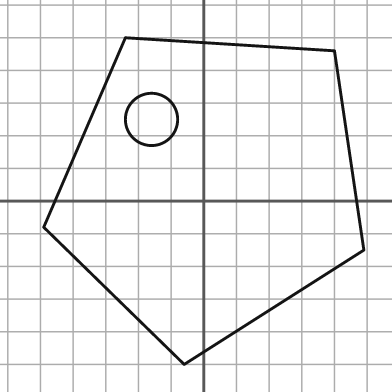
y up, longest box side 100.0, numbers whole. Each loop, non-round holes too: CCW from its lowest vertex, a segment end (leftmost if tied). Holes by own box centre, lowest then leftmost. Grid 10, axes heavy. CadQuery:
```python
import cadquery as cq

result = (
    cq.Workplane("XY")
    .moveTo(-6.0, -50.0)
    .lineTo(49.0, -15.0)
    .lineTo(40.0, 46.0)
    .lineTo(-24.0, 50.0)
    .lineTo(-49.0, -8.0)
    .close()
    .moveTo(-16.0, 25.0)
    .circle(8.0)
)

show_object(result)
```